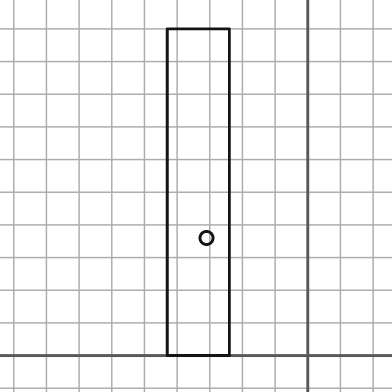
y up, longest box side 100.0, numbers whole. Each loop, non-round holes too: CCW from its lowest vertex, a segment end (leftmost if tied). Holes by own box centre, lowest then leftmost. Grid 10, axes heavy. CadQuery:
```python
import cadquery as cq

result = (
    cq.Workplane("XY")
    .moveTo(-43.0, 0.0)
    .lineTo(-24.0, 0.0)
    .lineTo(-24.0, 100.0)
    .lineTo(-43.0, 100.0)
    .close()
    .moveTo(-31.0, 36.0)
    .circle(2.0)
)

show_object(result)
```